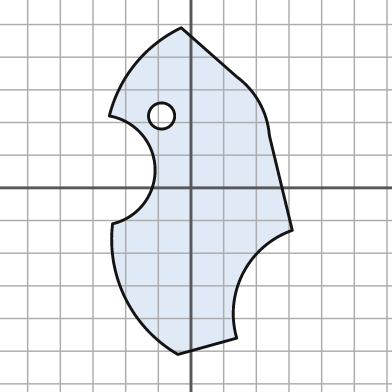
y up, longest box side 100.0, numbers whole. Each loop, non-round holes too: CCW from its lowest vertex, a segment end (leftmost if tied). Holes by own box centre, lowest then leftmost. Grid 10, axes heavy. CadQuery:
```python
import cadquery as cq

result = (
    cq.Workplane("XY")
    .moveTo(-4.0, -51.0)
    .lineTo(14.0, -46.0)
    .threePointArc((16.0, -26.0), (31.0, -13.0))
    .lineTo(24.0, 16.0)
    .threePointArc((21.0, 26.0), (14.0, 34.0))
    .lineTo(-3.0, 49.0)
    .threePointArc((-17.0, 38.0), (-25.0, 22.0))
    .threePointArc((-11.0, 6.0), (-24.0, -11.0))
    .threePointArc((-20.0, -34.0), (-4.0, -51.0))
    .close()
    .moveTo(-9.0, 22.0)
    .circle(4.0)
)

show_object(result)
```